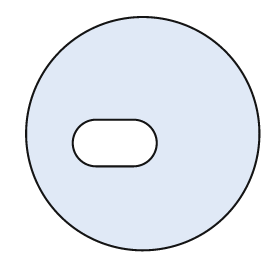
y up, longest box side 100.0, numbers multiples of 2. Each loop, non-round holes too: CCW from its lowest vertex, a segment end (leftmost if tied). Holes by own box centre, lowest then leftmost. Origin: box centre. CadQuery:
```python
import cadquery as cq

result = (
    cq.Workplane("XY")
    .moveTo(0.0, 0.0)
    .circle(50.0)
    .moveTo(-20.0, -14.0)
    .lineTo(-4.0, -14.0)
    .threePointArc((6.0, -4.0), (-4.0, 6.0))
    .lineTo(-20.0, 6.0)
    .threePointArc((-30.0, -4.0), (-20.0, -14.0))
    .close()
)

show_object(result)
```